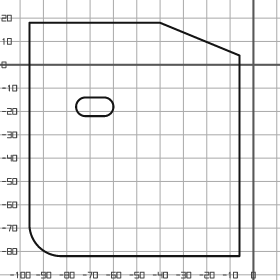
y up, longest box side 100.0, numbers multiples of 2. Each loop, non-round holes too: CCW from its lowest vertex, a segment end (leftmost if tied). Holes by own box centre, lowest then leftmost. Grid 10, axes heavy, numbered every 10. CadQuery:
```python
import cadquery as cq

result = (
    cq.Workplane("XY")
    .moveTo(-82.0, -82.0)
    .lineTo(-6.0, -82.0)
    .lineTo(-6.0, 4.0)
    .lineTo(-40.0, 18.0)
    .lineTo(-96.0, 18.0)
    .lineTo(-96.0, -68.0)
    .threePointArc((-92.0, -78.0), (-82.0, -82.0))
    .close()
    .moveTo(-72.0, -22.0)
    .lineTo(-64.0, -22.0)
    .threePointArc((-60.0, -18.0), (-64.0, -14.0))
    .lineTo(-72.0, -14.0)
    .threePointArc((-76.0, -18.0), (-72.0, -22.0))
    .close()
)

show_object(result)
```